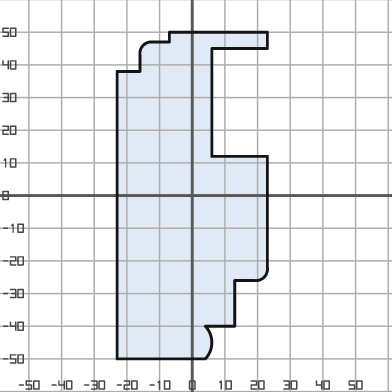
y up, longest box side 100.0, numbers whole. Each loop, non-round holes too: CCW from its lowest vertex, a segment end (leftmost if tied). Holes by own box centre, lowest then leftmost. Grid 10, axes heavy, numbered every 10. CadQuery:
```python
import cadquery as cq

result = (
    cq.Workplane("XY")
    .moveTo(-23.0, -50.0)
    .lineTo(4.0, -50.0)
    .threePointArc((6.0, -45.0), (4.0, -40.0))
    .lineTo(13.0, -40.0)
    .lineTo(13.0, -26.0)
    .lineTo(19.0, -26.0)
    .threePointArc((22.0, -25.0), (23.0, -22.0))
    .lineTo(23.0, 12.0)
    .lineTo(6.0, 12.0)
    .lineTo(6.0, 45.0)
    .lineTo(23.0, 45.0)
    .lineTo(23.0, 50.0)
    .lineTo(-7.0, 50.0)
    .lineTo(-7.0, 47.0)
    .lineTo(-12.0, 47.0)
    .threePointArc((-15.0, 46.0), (-16.0, 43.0))
    .lineTo(-16.0, 38.0)
    .lineTo(-23.0, 38.0)
    .close()
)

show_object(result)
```